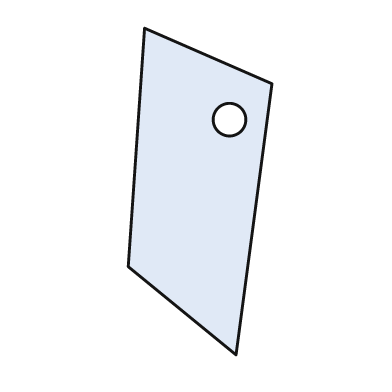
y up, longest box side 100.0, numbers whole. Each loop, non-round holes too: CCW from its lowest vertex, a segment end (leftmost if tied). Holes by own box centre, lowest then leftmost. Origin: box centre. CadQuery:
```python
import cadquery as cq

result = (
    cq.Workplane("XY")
    .moveTo(11.0, -50.0)
    .lineTo(22.0, 33.0)
    .lineTo(-17.0, 50.0)
    .lineTo(-22.0, -23.0)
    .close()
    .moveTo(9.0, 22.0)
    .circle(5.0)
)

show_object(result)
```